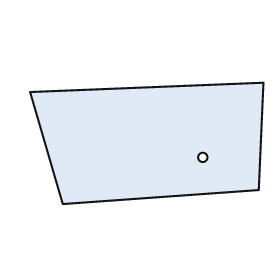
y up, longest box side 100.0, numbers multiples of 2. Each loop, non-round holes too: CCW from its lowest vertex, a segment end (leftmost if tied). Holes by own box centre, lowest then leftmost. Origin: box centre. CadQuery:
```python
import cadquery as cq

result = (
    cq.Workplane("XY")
    .moveTo(-36.0, -26.0)
    .lineTo(48.0, -20.0)
    .lineTo(50.0, 26.0)
    .lineTo(-50.0, 22.0)
    .close()
    .moveTo(24.0, -6.0)
    .circle(2.0)
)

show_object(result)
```